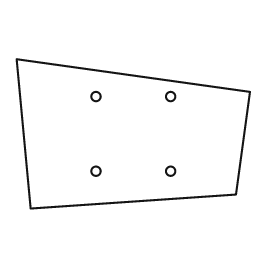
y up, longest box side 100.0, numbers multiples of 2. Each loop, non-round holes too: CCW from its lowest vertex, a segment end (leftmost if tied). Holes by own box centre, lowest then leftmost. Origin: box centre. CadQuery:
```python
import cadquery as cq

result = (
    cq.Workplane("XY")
    .moveTo(-44.0, -32.0)
    .lineTo(44.0, -26.0)
    .lineTo(50.0, 18.0)
    .lineTo(-50.0, 32.0)
    .close()
    .moveTo(-16.0, -16.0)
    .circle(2.0)
    .moveTo(16.0, -16.0)
    .circle(2.0)
    .moveTo(-16.0, 16.0)
    .circle(2.0)
    .moveTo(16.0, 16.0)
    .circle(2.0)
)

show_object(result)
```